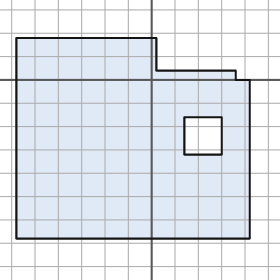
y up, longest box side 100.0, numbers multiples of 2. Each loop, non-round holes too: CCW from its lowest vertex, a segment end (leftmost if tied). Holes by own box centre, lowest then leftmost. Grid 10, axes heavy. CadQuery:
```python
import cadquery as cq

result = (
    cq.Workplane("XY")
    .moveTo(-58.0, -68.0)
    .lineTo(42.0, -68.0)
    .lineTo(42.0, 0.0)
    .lineTo(36.0, 0.0)
    .lineTo(36.0, 4.0)
    .lineTo(2.0, 4.0)
    .lineTo(2.0, 18.0)
    .lineTo(-58.0, 18.0)
    .close()
    .moveTo(14.0, -32.0)
    .lineTo(30.0, -32.0)
    .lineTo(30.0, -16.0)
    .lineTo(14.0, -16.0)
    .close()
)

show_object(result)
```